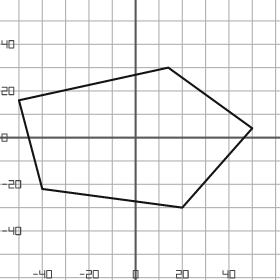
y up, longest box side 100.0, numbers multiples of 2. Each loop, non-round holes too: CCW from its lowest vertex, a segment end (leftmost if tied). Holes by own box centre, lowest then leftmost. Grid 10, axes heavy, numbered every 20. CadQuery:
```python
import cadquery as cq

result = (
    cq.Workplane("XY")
    .moveTo(20.0, -30.0)
    .lineTo(50.0, 4.0)
    .lineTo(14.0, 30.0)
    .lineTo(-50.0, 16.0)
    .lineTo(-40.0, -22.0)
    .close()
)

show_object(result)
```